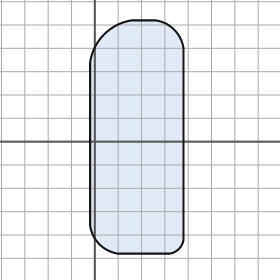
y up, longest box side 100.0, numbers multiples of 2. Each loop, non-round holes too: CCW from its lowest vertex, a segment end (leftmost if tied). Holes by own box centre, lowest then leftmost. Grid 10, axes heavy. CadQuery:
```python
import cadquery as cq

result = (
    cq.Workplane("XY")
    .moveTo(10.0, -48.0)
    .lineTo(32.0, -48.0)
    .threePointArc((36.0, -46.0), (38.0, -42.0))
    .lineTo(38.0, 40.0)
    .threePointArc((34.0, 48.0), (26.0, 52.0))
    .lineTo(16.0, 52.0)
    .threePointArc((4.0, 46.0), (-2.0, 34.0))
    .lineTo(-2.0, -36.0)
    .threePointArc((2.0, -44.0), (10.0, -48.0))
    .close()
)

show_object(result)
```